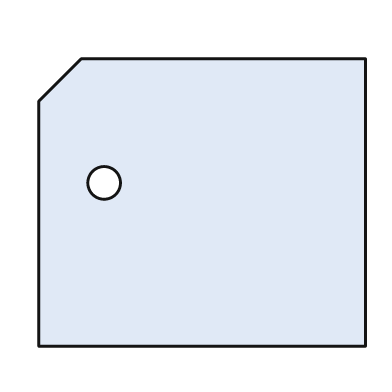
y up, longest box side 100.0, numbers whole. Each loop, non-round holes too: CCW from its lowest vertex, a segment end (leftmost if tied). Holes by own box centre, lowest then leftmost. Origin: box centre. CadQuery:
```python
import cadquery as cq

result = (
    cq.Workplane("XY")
    .moveTo(-50.0, -44.0)
    .lineTo(50.0, -44.0)
    .lineTo(50.0, 44.0)
    .lineTo(-37.0, 44.0)
    .lineTo(-50.0, 31.0)
    .close()
    .moveTo(-30.0, 6.0)
    .circle(5.0)
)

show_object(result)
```